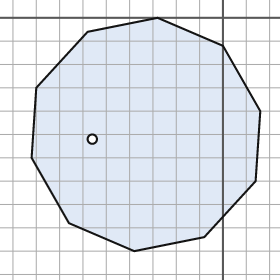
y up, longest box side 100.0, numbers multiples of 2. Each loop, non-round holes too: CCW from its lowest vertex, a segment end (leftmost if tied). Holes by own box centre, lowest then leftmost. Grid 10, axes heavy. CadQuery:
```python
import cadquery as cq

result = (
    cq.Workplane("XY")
    .moveTo(-38.0, -100.0)
    .lineTo(-8.0, -94.0)
    .lineTo(14.0, -70.0)
    .lineTo(16.0, -40.0)
    .lineTo(0.0, -12.0)
    .lineTo(-28.0, 0.0)
    .lineTo(-58.0, -6.0)
    .lineTo(-80.0, -30.0)
    .lineTo(-82.0, -60.0)
    .lineTo(-66.0, -88.0)
    .close()
    .moveTo(-56.0, -52.0)
    .circle(2.0)
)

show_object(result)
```